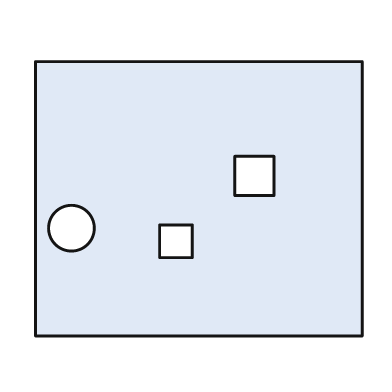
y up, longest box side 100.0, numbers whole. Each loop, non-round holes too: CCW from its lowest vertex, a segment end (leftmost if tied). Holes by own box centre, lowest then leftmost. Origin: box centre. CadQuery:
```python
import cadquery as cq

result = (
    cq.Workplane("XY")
    .moveTo(-50.0, -42.0)
    .lineTo(50.0, -42.0)
    .lineTo(50.0, 42.0)
    .lineTo(-50.0, 42.0)
    .close()
    .moveTo(-12.0, -18.0)
    .lineTo(-2.0, -18.0)
    .lineTo(-2.0, -8.0)
    .lineTo(-12.0, -8.0)
    .close()
    .moveTo(-39.0, -9.0)
    .circle(7.0)
    .moveTo(11.0, 1.0)
    .lineTo(23.0, 1.0)
    .lineTo(23.0, 13.0)
    .lineTo(11.0, 13.0)
    .close()
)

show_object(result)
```